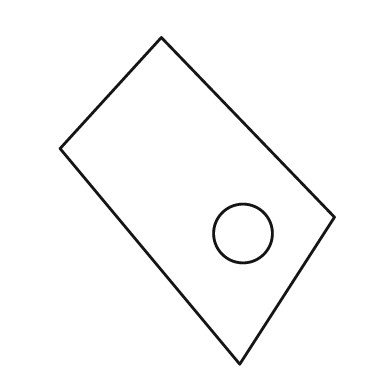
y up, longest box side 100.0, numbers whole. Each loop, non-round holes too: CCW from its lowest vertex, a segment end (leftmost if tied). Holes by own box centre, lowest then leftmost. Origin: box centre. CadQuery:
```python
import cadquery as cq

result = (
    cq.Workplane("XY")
    .moveTo(13.0, -50.0)
    .lineTo(42.0, -5.0)
    .lineTo(-11.0, 50.0)
    .lineTo(-42.0, 16.0)
    .close()
    .moveTo(14.0, -10.0)
    .circle(9.0)
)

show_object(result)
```